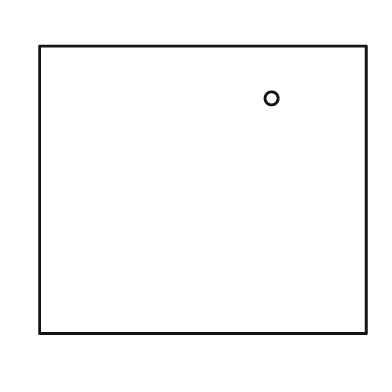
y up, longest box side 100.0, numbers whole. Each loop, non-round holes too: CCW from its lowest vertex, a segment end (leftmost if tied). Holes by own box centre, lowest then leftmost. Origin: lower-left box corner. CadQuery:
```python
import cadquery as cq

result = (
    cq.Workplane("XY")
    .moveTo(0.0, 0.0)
    .lineTo(100.0, 0.0)
    .lineTo(100.0, 88.0)
    .lineTo(0.0, 88.0)
    .close()
    .moveTo(71.0, 72.0)
    .circle(2.0)
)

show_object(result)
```